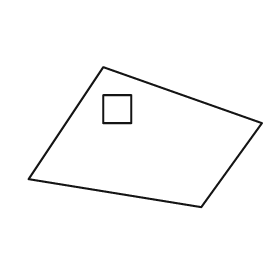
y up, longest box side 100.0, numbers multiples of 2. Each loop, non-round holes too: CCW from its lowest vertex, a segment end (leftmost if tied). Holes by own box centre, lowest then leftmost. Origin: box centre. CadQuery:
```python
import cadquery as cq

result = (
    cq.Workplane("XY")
    .moveTo(24.0, -30.0)
    .lineTo(50.0, 6.0)
    .lineTo(-18.0, 30.0)
    .lineTo(-50.0, -18.0)
    .close()
    .moveTo(-18.0, 6.0)
    .lineTo(-6.0, 6.0)
    .lineTo(-6.0, 18.0)
    .lineTo(-18.0, 18.0)
    .close()
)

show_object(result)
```